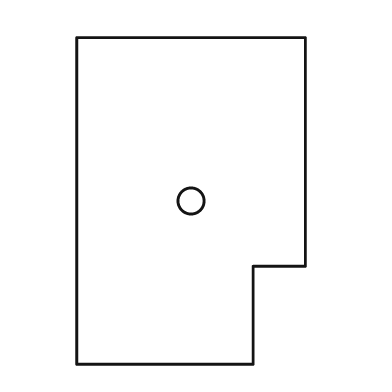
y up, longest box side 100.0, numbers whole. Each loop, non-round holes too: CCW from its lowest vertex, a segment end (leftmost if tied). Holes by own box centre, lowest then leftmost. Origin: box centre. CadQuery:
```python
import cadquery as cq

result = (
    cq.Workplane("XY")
    .moveTo(-35.0, -50.0)
    .lineTo(19.0, -50.0)
    .lineTo(19.0, -20.0)
    .lineTo(35.0, -20.0)
    .lineTo(35.0, 50.0)
    .lineTo(-35.0, 50.0)
    .close()
    .moveTo(0.0, 0.0)
    .circle(4.0)
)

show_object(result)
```